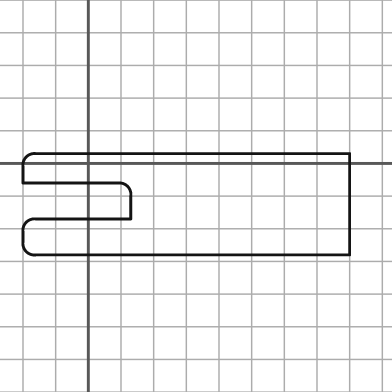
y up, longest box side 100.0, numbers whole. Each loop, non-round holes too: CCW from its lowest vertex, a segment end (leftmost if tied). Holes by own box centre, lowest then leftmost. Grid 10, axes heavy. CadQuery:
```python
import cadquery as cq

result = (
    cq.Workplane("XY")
    .moveTo(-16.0, -28.0)
    .lineTo(80.0, -28.0)
    .lineTo(80.0, 3.0)
    .lineTo(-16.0, 3.0)
    .threePointArc((-19.0, 2.0), (-20.0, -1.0))
    .lineTo(-20.0, -6.0)
    .lineTo(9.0, -6.0)
    .threePointArc((12.0, -7.0), (13.0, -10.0))
    .lineTo(13.0, -17.0)
    .lineTo(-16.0, -17.0)
    .threePointArc((-19.0, -18.0), (-20.0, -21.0))
    .lineTo(-20.0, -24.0)
    .threePointArc((-19.0, -27.0), (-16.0, -28.0))
    .close()
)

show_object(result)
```